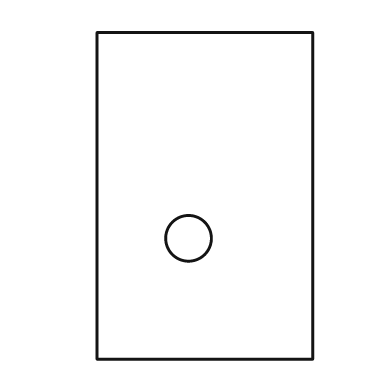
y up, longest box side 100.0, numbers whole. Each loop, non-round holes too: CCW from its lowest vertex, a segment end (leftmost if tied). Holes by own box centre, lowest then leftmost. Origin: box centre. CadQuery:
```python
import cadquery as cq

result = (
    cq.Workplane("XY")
    .moveTo(-33.0, -50.0)
    .lineTo(33.0, -50.0)
    .lineTo(33.0, 50.0)
    .lineTo(-33.0, 50.0)
    .close()
    .moveTo(-5.0, -13.0)
    .circle(7.0)
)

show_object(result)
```